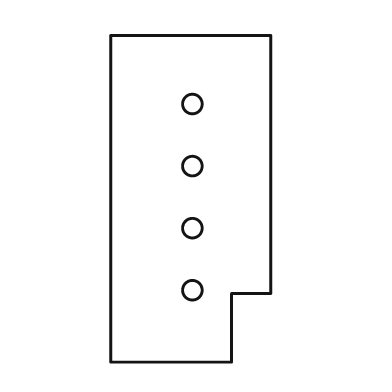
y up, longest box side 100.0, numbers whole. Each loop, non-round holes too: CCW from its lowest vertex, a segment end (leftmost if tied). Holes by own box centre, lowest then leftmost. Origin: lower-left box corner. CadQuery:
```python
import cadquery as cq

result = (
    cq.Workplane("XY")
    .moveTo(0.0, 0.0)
    .lineTo(37.0, 0.0)
    .lineTo(37.0, 21.0)
    .lineTo(49.0, 21.0)
    .lineTo(49.0, 100.0)
    .lineTo(0.0, 100.0)
    .close()
    .moveTo(25.0, 22.0)
    .circle(3.0)
    .moveTo(25.0, 41.0)
    .circle(3.0)
    .moveTo(25.0, 60.0)
    .circle(3.0)
    .moveTo(25.0, 79.0)
    .circle(3.0)
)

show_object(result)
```